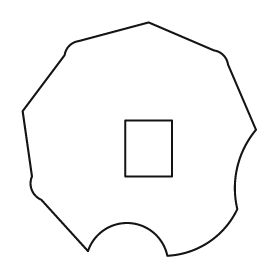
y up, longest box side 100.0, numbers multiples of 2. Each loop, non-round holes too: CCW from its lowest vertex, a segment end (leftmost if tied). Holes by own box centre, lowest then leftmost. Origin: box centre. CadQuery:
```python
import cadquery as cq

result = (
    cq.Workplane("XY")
    .moveTo(12.0, -50.0)
    .threePointArc((30.0, -44.0), (42.0, -30.0))
    .threePointArc((42.0, -12.0), (50.0, 4.0))
    .lineTo(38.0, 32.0)
    .threePointArc((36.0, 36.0), (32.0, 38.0))
    .lineTo(4.0, 50.0)
    .lineTo(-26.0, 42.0)
    .threePointArc((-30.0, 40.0), (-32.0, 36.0))
    .lineTo(-50.0, 12.0)
    .lineTo(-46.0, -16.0)
    .threePointArc((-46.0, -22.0), (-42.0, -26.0))
    .lineTo(-22.0, -48.0)
    .threePointArc((-4.0, -36.0), (12.0, -50.0))
    .close()
    .moveTo(-6.0, -16.0)
    .lineTo(14.0, -16.0)
    .lineTo(14.0, 8.0)
    .lineTo(-6.0, 8.0)
    .close()
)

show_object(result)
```